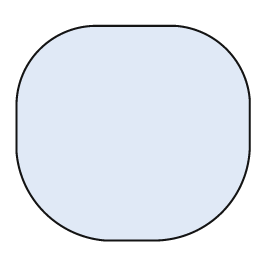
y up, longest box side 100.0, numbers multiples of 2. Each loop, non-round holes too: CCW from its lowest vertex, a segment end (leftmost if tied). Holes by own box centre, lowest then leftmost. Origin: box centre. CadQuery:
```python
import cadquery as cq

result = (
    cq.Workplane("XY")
    .moveTo(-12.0, -46.0)
    .lineTo(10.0, -46.0)
    .threePointArc((38.0, -34.0), (50.0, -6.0))
    .lineTo(50.0, 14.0)
    .threePointArc((40.0, 36.0), (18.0, 46.0))
    .lineTo(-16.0, 46.0)
    .threePointArc((-40.0, 36.0), (-50.0, 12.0))
    .lineTo(-50.0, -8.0)
    .threePointArc((-38.0, -34.0), (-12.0, -46.0))
    .close()
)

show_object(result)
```